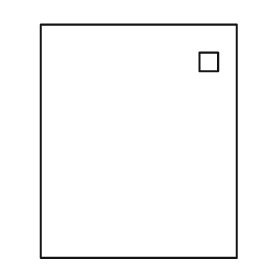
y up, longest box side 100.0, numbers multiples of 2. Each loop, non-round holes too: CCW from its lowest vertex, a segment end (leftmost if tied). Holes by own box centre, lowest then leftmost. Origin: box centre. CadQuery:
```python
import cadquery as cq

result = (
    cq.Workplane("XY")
    .moveTo(-42.0, -50.0)
    .lineTo(42.0, -50.0)
    .lineTo(42.0, 50.0)
    .lineTo(-42.0, 50.0)
    .close()
    .moveTo(26.0, 30.0)
    .lineTo(34.0, 30.0)
    .lineTo(34.0, 38.0)
    .lineTo(26.0, 38.0)
    .close()
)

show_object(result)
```